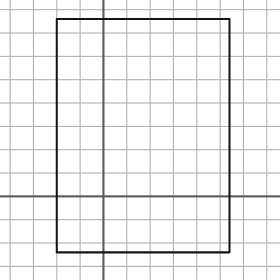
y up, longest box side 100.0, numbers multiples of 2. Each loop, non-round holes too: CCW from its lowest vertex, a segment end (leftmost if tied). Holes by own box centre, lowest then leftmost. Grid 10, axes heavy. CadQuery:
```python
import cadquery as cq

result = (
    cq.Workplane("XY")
    .moveTo(-20.0, -24.0)
    .lineTo(54.0, -24.0)
    .lineTo(54.0, 76.0)
    .lineTo(-20.0, 76.0)
    .close()
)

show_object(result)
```